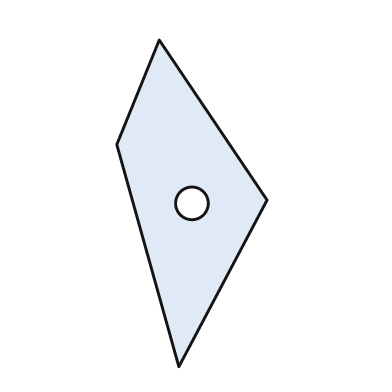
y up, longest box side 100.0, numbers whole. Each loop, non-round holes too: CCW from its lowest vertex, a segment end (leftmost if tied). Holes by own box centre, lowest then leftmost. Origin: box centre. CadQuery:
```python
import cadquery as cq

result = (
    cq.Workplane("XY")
    .moveTo(-4.0, -50.0)
    .lineTo(23.0, 1.0)
    .lineTo(-10.0, 50.0)
    .lineTo(-23.0, 18.0)
    .close()
    .moveTo(0.0, 0.0)
    .circle(5.0)
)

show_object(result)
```